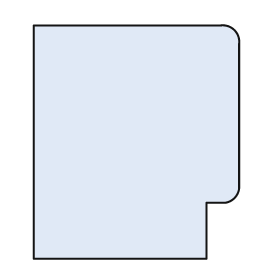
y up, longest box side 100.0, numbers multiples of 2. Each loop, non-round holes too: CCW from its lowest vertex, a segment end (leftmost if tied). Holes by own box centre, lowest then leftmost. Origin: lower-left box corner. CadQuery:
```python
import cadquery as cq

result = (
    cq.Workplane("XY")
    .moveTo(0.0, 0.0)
    .lineTo(74.0, 0.0)
    .lineTo(74.0, 24.0)
    .lineTo(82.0, 24.0)
    .threePointArc((86.0, 26.0), (88.0, 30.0))
    .lineTo(88.0, 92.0)
    .threePointArc((86.0, 98.0), (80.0, 100.0))
    .lineTo(0.0, 100.0)
    .close()
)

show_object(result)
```